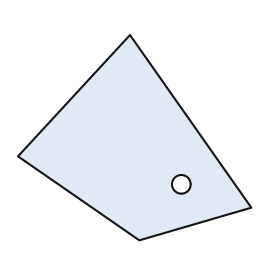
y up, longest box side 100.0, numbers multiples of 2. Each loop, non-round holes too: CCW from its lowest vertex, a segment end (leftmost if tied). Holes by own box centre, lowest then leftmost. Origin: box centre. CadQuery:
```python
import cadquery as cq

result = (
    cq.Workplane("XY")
    .moveTo(2.0, -44.0)
    .lineTo(50.0, -30.0)
    .lineTo(-2.0, 44.0)
    .lineTo(-50.0, -8.0)
    .close()
    .moveTo(20.0, -20.0)
    .circle(4.0)
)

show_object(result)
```